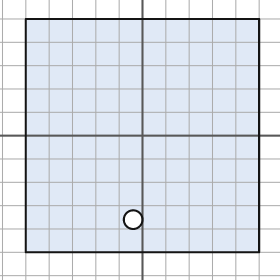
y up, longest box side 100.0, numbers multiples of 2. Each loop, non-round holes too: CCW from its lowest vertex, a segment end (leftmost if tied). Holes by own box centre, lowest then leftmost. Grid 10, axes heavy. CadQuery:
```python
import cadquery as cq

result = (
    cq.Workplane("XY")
    .moveTo(-50.0, -50.0)
    .lineTo(50.0, -50.0)
    .lineTo(50.0, 50.0)
    .lineTo(-50.0, 50.0)
    .close()
    .moveTo(-4.0, -36.0)
    .circle(4.0)
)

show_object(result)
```